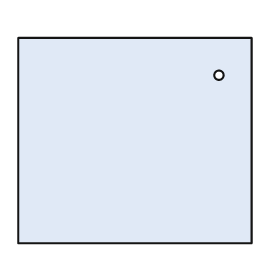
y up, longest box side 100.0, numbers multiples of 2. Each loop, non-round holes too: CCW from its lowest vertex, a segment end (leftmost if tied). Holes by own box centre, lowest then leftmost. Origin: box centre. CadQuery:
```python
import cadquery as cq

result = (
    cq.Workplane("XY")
    .moveTo(-50.0, -44.0)
    .lineTo(50.0, -44.0)
    .lineTo(50.0, 44.0)
    .lineTo(-50.0, 44.0)
    .close()
    .moveTo(36.0, 28.0)
    .circle(2.0)
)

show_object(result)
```